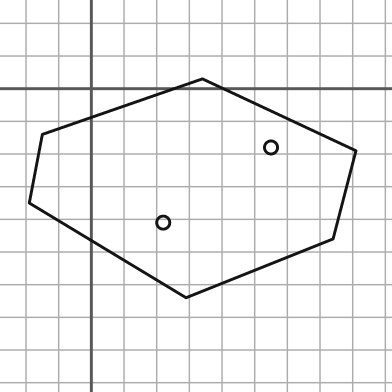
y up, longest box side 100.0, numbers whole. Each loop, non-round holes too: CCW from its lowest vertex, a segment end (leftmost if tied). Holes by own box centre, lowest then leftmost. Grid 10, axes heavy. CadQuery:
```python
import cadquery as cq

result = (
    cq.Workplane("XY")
    .moveTo(29.0, -64.0)
    .lineTo(74.0, -46.0)
    .lineTo(81.0, -19.0)
    .lineTo(34.0, 3.0)
    .lineTo(-15.0, -14.0)
    .lineTo(-19.0, -35.0)
    .close()
    .moveTo(22.0, -41.0)
    .circle(2.0)
    .moveTo(55.0, -18.0)
    .circle(2.0)
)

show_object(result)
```